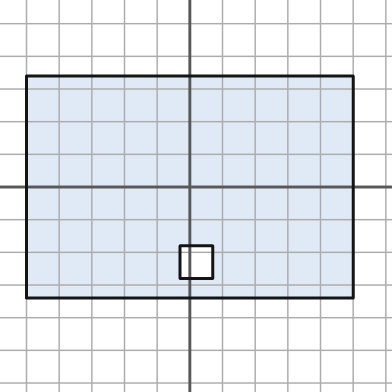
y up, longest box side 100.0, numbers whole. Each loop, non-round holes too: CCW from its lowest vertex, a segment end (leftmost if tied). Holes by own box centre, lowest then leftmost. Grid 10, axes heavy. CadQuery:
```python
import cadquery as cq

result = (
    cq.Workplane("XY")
    .moveTo(-50.0, -34.0)
    .lineTo(50.0, -34.0)
    .lineTo(50.0, 34.0)
    .lineTo(-50.0, 34.0)
    .close()
    .moveTo(-3.0, -28.0)
    .lineTo(7.0, -28.0)
    .lineTo(7.0, -18.0)
    .lineTo(-3.0, -18.0)
    .close()
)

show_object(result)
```